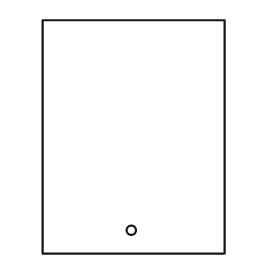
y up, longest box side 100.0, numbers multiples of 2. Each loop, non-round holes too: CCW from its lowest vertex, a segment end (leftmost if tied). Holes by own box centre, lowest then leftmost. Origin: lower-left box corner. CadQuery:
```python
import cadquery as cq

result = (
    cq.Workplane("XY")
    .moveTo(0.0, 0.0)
    .lineTo(78.0, 0.0)
    .lineTo(78.0, 100.0)
    .lineTo(0.0, 100.0)
    .close()
    .moveTo(38.0, 10.0)
    .circle(2.0)
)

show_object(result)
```